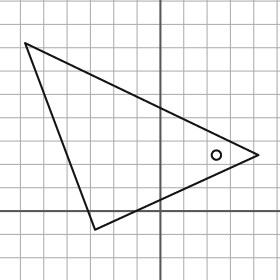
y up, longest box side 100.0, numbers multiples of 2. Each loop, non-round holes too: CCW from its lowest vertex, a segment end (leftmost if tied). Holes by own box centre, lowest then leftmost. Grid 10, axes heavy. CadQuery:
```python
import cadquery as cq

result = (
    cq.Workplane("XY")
    .moveTo(-28.0, -8.0)
    .lineTo(42.0, 24.0)
    .lineTo(-58.0, 72.0)
    .close()
    .moveTo(24.0, 24.0)
    .circle(2.0)
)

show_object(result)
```